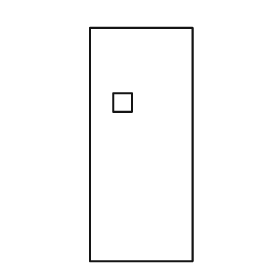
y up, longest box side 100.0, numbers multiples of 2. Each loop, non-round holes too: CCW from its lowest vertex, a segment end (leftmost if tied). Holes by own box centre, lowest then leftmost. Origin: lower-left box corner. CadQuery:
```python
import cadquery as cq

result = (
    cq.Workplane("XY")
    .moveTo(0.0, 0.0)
    .lineTo(44.0, 0.0)
    .lineTo(44.0, 100.0)
    .lineTo(0.0, 100.0)
    .close()
    .moveTo(10.0, 64.0)
    .lineTo(18.0, 64.0)
    .lineTo(18.0, 72.0)
    .lineTo(10.0, 72.0)
    .close()
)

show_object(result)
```